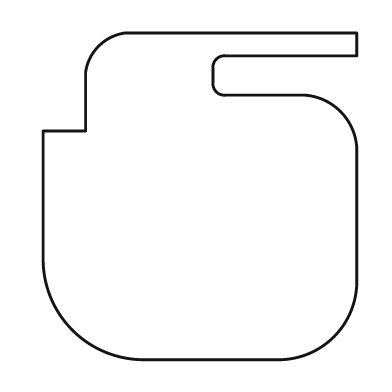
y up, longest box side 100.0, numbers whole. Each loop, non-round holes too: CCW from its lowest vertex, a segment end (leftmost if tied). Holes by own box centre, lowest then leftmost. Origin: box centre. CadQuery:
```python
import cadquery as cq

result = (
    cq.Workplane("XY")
    .moveTo(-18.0, -50.0)
    .lineTo(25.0, -50.0)
    .threePointArc((41.0, -43.0), (48.0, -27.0))
    .lineTo(48.0, 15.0)
    .threePointArc((43.0, 26.0), (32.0, 31.0))
    .lineTo(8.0, 31.0)
    .threePointArc((5.0, 32.0), (4.0, 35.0))
    .lineTo(4.0, 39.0)
    .threePointArc((5.0, 42.0), (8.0, 43.0))
    .lineTo(48.0, 43.0)
    .lineTo(48.0, 50.0)
    .lineTo(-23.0, 50.0)
    .threePointArc((-31.0, 46.0), (-35.0, 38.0))
    .lineTo(-35.0, 20.0)
    .lineTo(-48.0, 20.0)
    .lineTo(-48.0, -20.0)
    .threePointArc((-39.0, -41.0), (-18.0, -50.0))
    .close()
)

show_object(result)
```